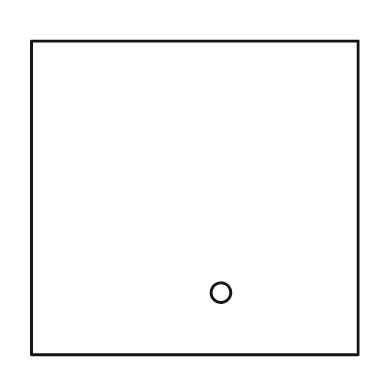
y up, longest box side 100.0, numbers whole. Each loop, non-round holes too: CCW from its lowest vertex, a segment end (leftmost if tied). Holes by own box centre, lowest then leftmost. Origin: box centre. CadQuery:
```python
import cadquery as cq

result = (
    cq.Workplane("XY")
    .moveTo(-50.0, -48.0)
    .lineTo(50.0, -48.0)
    .lineTo(50.0, 48.0)
    .lineTo(-50.0, 48.0)
    .close()
    .moveTo(8.0, -29.0)
    .circle(3.0)
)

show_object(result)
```